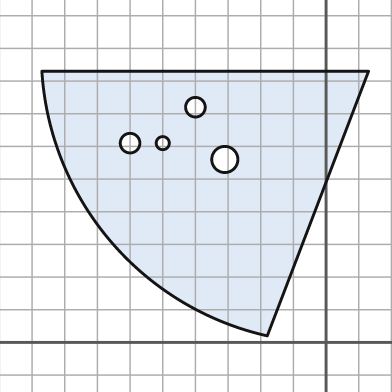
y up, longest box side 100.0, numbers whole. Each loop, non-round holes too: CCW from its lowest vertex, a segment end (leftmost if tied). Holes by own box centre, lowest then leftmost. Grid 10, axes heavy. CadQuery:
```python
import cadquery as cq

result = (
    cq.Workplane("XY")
    .moveTo(-18.0, 2.0)
    .lineTo(13.0, 83.0)
    .lineTo(-87.0, 83.0)
    .threePointArc((-66.0, 31.0), (-18.0, 2.0))
    .close()
    .moveTo(-31.0, 56.0)
    .circle(4.0)
    .moveTo(-60.0, 61.0)
    .circle(3.0)
    .moveTo(-50.0, 61.0)
    .circle(2.0)
    .moveTo(-40.0, 72.0)
    .circle(3.0)
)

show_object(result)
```